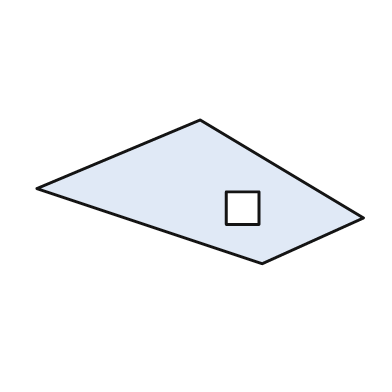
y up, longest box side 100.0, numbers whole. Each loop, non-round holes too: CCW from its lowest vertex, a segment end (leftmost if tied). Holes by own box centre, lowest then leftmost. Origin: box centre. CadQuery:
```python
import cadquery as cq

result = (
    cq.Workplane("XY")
    .moveTo(19.0, -22.0)
    .lineTo(50.0, -8.0)
    .lineTo(0.0, 22.0)
    .lineTo(-50.0, 1.0)
    .close()
    .moveTo(8.0, -10.0)
    .lineTo(18.0, -10.0)
    .lineTo(18.0, 0.0)
    .lineTo(8.0, 0.0)
    .close()
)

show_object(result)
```